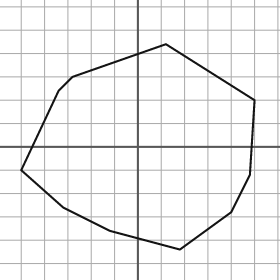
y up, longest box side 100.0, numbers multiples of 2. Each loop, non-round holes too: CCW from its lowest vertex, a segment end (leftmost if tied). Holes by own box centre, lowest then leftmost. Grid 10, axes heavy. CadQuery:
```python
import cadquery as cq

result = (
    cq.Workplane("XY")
    .moveTo(18.0, -44.0)
    .lineTo(40.0, -28.0)
    .lineTo(48.0, -12.0)
    .lineTo(50.0, 20.0)
    .lineTo(12.0, 44.0)
    .lineTo(-28.0, 30.0)
    .lineTo(-34.0, 24.0)
    .lineTo(-50.0, -10.0)
    .lineTo(-32.0, -26.0)
    .lineTo(-12.0, -36.0)
    .close()
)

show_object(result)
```